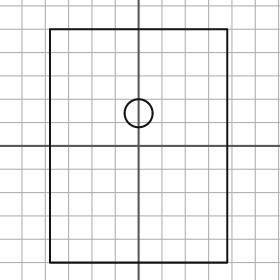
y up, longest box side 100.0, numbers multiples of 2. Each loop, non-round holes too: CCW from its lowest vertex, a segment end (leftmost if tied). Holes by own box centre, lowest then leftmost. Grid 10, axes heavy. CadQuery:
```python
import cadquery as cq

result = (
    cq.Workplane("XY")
    .moveTo(-38.0, -50.0)
    .lineTo(38.0, -50.0)
    .lineTo(38.0, 50.0)
    .lineTo(-38.0, 50.0)
    .close()
    .moveTo(0.0, 14.0)
    .circle(6.0)
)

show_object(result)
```